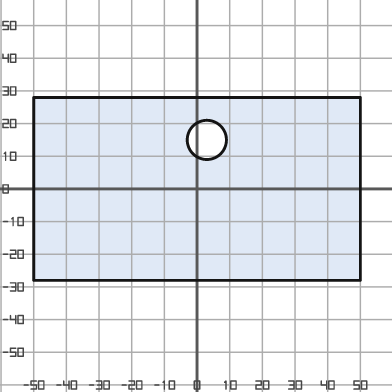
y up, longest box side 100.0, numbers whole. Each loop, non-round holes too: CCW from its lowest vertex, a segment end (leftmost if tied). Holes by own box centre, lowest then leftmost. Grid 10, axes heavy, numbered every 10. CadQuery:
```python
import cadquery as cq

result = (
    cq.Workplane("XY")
    .moveTo(-50.0, -28.0)
    .lineTo(50.0, -28.0)
    .lineTo(50.0, 28.0)
    .lineTo(-50.0, 28.0)
    .close()
    .moveTo(3.0, 15.0)
    .circle(6.0)
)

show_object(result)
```